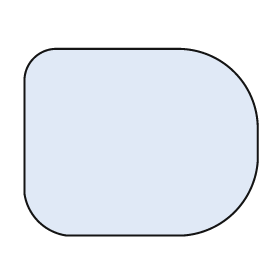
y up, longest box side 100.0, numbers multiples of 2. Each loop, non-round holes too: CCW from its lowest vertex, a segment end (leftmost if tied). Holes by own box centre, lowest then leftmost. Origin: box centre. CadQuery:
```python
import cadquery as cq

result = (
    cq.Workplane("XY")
    .moveTo(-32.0, -40.0)
    .lineTo(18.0, -40.0)
    .threePointArc((40.0, -30.0), (50.0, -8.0))
    .lineTo(50.0, 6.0)
    .threePointArc((40.0, 30.0), (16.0, 40.0))
    .lineTo(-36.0, 40.0)
    .threePointArc((-46.0, 36.0), (-50.0, 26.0))
    .lineTo(-50.0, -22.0)
    .threePointArc((-44.0, -34.0), (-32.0, -40.0))
    .close()
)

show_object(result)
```